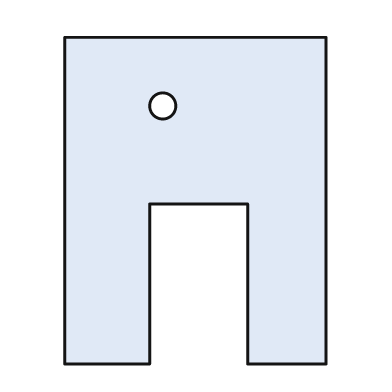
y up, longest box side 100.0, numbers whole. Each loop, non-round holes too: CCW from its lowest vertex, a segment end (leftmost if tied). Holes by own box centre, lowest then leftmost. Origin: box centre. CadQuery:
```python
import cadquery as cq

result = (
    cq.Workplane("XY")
    .moveTo(-40.0, -50.0)
    .lineTo(-14.0, -50.0)
    .lineTo(-14.0, -1.0)
    .lineTo(16.0, -1.0)
    .lineTo(16.0, -50.0)
    .lineTo(40.0, -50.0)
    .lineTo(40.0, 50.0)
    .lineTo(-40.0, 50.0)
    .close()
    .moveTo(-10.0, 29.0)
    .circle(4.0)
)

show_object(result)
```